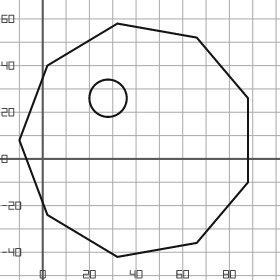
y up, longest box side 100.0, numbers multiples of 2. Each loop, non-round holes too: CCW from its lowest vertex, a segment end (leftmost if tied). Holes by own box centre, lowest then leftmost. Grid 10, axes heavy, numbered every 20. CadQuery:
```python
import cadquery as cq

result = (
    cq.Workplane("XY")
    .moveTo(32.0, -42.0)
    .lineTo(66.0, -36.0)
    .lineTo(88.0, -10.0)
    .lineTo(88.0, 26.0)
    .lineTo(66.0, 52.0)
    .lineTo(32.0, 58.0)
    .lineTo(2.0, 40.0)
    .lineTo(-10.0, 8.0)
    .lineTo(2.0, -24.0)
    .close()
    .moveTo(28.0, 26.0)
    .circle(8.0)
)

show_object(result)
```